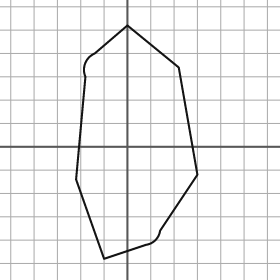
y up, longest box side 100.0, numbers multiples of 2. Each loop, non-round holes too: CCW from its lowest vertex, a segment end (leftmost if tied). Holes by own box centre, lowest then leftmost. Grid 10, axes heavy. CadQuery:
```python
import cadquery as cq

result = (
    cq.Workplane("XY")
    .moveTo(-10.0, -48.0)
    .lineTo(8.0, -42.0)
    .threePointArc((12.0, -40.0), (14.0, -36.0))
    .lineTo(30.0, -12.0)
    .lineTo(22.0, 34.0)
    .lineTo(0.0, 52.0)
    .lineTo(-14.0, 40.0)
    .threePointArc((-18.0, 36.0), (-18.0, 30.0))
    .lineTo(-22.0, -14.0)
    .close()
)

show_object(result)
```